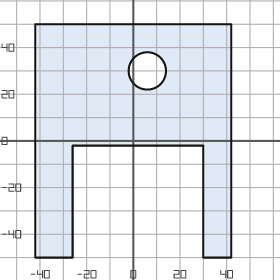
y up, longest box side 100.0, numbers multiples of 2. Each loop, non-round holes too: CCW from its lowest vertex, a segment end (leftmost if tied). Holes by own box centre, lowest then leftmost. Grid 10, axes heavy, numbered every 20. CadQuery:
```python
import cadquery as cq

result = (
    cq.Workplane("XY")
    .moveTo(-42.0, -50.0)
    .lineTo(-26.0, -50.0)
    .lineTo(-26.0, -2.0)
    .lineTo(30.0, -2.0)
    .lineTo(30.0, -50.0)
    .lineTo(42.0, -50.0)
    .lineTo(42.0, 50.0)
    .lineTo(-42.0, 50.0)
    .close()
    .moveTo(6.0, 30.0)
    .circle(8.0)
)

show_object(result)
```